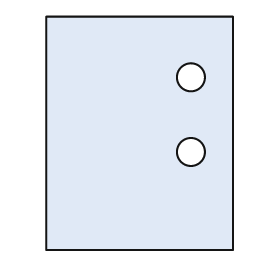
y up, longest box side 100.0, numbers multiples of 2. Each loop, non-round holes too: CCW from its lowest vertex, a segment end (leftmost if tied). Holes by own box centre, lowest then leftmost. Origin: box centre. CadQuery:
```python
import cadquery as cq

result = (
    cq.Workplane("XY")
    .moveTo(-40.0, -50.0)
    .lineTo(40.0, -50.0)
    .lineTo(40.0, 50.0)
    .lineTo(-40.0, 50.0)
    .close()
    .moveTo(22.0, -8.0)
    .circle(6.0)
    .moveTo(22.0, 24.0)
    .circle(6.0)
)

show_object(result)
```